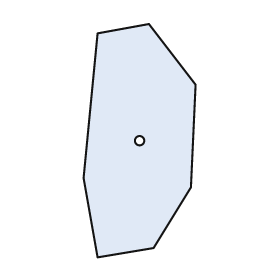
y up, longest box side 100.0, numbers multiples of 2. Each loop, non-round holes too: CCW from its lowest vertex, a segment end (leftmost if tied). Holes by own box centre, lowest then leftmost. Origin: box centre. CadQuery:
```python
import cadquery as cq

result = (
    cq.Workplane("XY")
    .moveTo(-18.0, -50.0)
    .lineTo(6.0, -46.0)
    .lineTo(22.0, -20.0)
    .lineTo(24.0, 24.0)
    .lineTo(4.0, 50.0)
    .lineTo(-18.0, 46.0)
    .lineTo(-24.0, -16.0)
    .close()
    .moveTo(0.0, 0.0)
    .circle(2.0)
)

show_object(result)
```